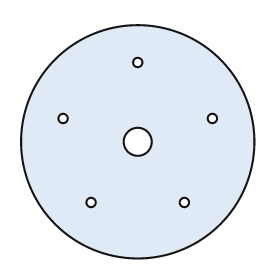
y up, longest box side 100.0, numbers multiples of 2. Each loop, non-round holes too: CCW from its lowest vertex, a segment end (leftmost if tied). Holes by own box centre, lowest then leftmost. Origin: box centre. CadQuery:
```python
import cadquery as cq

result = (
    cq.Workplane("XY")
    .moveTo(0.0, 0.0)
    .circle(50.0)
    .moveTo(-20.0, -26.0)
    .circle(2.0)
    .moveTo(20.0, -26.0)
    .circle(2.0)
    .moveTo(0.0, 0.0)
    .circle(6.0)
    .moveTo(-32.0, 10.0)
    .circle(2.0)
    .moveTo(32.0, 10.0)
    .circle(2.0)
    .moveTo(0.0, 34.0)
    .circle(2.0)
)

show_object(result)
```